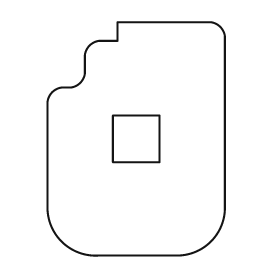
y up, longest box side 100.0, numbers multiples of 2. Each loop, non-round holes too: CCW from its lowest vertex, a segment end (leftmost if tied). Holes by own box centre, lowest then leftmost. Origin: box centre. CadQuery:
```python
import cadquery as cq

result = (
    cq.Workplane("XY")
    .moveTo(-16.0, -50.0)
    .lineTo(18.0, -50.0)
    .threePointArc((32.0, -44.0), (38.0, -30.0))
    .lineTo(38.0, 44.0)
    .threePointArc((36.0, 48.0), (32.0, 50.0))
    .lineTo(-8.0, 50.0)
    .lineTo(-8.0, 42.0)
    .lineTo(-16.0, 42.0)
    .threePointArc((-20.0, 40.0), (-22.0, 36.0))
    .lineTo(-22.0, 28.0)
    .threePointArc((-24.0, 24.0), (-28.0, 22.0))
    .lineTo(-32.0, 22.0)
    .threePointArc((-36.0, 20.0), (-38.0, 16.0))
    .lineTo(-38.0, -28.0)
    .threePointArc((-32.0, -44.0), (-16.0, -50.0))
    .close()
    .moveTo(-10.0, -10.0)
    .lineTo(10.0, -10.0)
    .lineTo(10.0, 10.0)
    .lineTo(-10.0, 10.0)
    .close()
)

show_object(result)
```